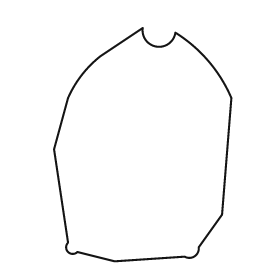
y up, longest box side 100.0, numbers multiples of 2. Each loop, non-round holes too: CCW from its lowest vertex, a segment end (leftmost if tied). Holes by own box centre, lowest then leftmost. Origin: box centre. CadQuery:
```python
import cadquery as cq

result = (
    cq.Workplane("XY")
    .moveTo(-12.0, -50.0)
    .lineTo(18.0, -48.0)
    .threePointArc((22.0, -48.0), (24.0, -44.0))
    .lineTo(34.0, -30.0)
    .lineTo(38.0, 20.0)
    .threePointArc((28.0, 36.0), (14.0, 48.0))
    .threePointArc((6.0, 42.0), (0.0, 50.0))
    .lineTo(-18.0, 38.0)
    .threePointArc((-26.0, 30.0), (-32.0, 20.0))
    .lineTo(-38.0, -2.0)
    .lineTo(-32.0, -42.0)
    .threePointArc((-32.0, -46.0), (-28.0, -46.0))
    .close()
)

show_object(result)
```